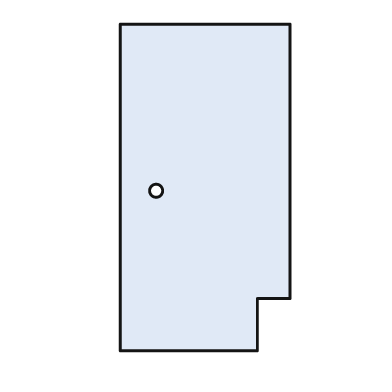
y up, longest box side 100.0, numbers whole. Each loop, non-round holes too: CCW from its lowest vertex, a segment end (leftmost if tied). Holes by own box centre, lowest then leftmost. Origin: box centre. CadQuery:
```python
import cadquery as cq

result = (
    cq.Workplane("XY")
    .moveTo(-26.0, -50.0)
    .lineTo(16.0, -50.0)
    .lineTo(16.0, -34.0)
    .lineTo(26.0, -34.0)
    .lineTo(26.0, 50.0)
    .lineTo(-26.0, 50.0)
    .close()
    .moveTo(-15.0, -1.0)
    .circle(2.0)
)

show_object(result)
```